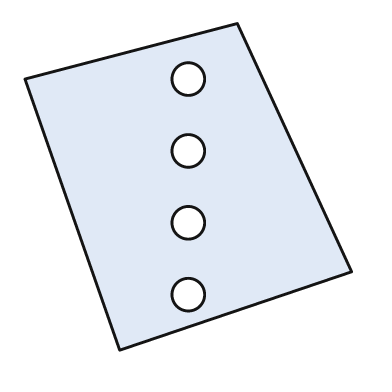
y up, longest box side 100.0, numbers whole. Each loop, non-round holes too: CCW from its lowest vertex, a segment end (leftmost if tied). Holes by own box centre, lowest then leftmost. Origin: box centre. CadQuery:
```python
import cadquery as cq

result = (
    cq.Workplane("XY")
    .moveTo(-21.0, -50.0)
    .lineTo(50.0, -26.0)
    .lineTo(15.0, 50.0)
    .lineTo(-50.0, 33.0)
    .close()
    .moveTo(0.0, -33.0)
    .circle(5.0)
    .moveTo(0.0, -11.0)
    .circle(5.0)
    .moveTo(0.0, 11.0)
    .circle(5.0)
    .moveTo(0.0, 33.0)
    .circle(5.0)
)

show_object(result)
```